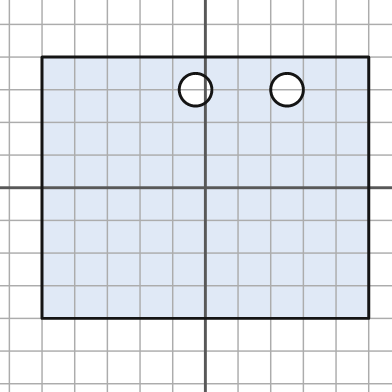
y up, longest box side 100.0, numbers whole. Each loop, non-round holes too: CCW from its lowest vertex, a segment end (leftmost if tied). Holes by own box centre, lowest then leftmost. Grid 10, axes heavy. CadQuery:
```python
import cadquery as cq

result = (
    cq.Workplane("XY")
    .moveTo(-50.0, -40.0)
    .lineTo(50.0, -40.0)
    .lineTo(50.0, 40.0)
    .lineTo(-50.0, 40.0)
    .close()
    .moveTo(-3.0, 30.0)
    .circle(5.0)
    .moveTo(25.0, 30.0)
    .circle(5.0)
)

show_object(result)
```